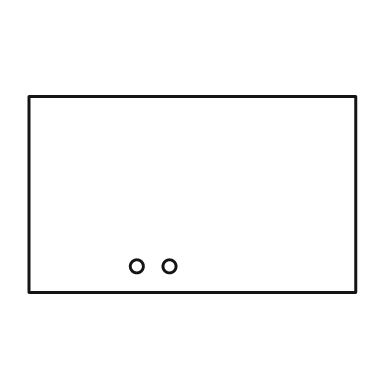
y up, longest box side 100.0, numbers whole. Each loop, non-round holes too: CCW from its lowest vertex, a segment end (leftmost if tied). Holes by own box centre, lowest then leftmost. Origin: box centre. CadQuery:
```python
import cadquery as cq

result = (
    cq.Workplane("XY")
    .moveTo(-50.0, -30.0)
    .lineTo(50.0, -30.0)
    .lineTo(50.0, 30.0)
    .lineTo(-50.0, 30.0)
    .close()
    .moveTo(-17.0, -22.0)
    .circle(2.0)
    .moveTo(-7.0, -22.0)
    .circle(2.0)
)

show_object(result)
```